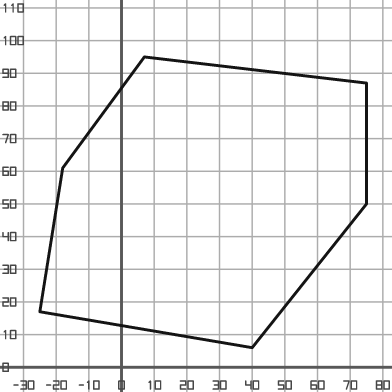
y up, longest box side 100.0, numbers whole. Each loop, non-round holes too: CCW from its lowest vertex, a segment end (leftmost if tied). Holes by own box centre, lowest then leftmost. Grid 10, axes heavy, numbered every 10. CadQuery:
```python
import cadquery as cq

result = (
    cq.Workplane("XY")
    .moveTo(40.0, 6.0)
    .lineTo(75.0, 50.0)
    .lineTo(75.0, 87.0)
    .lineTo(7.0, 95.0)
    .lineTo(-18.0, 61.0)
    .lineTo(-25.0, 17.0)
    .close()
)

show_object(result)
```